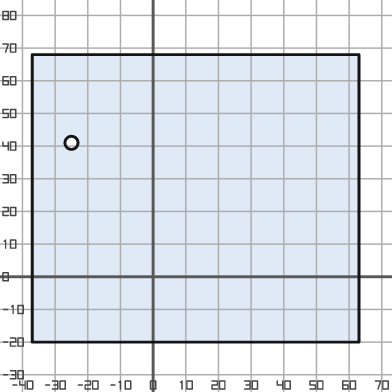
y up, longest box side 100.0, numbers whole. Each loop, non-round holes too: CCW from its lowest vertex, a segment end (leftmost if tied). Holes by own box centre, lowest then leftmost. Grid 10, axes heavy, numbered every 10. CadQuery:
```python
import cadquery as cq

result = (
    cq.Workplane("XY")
    .moveTo(-37.0, -20.0)
    .lineTo(63.0, -20.0)
    .lineTo(63.0, 68.0)
    .lineTo(-37.0, 68.0)
    .close()
    .moveTo(-25.0, 41.0)
    .circle(2.0)
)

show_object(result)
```